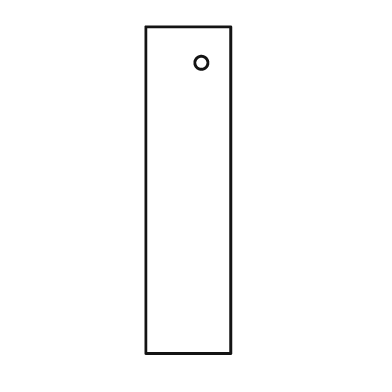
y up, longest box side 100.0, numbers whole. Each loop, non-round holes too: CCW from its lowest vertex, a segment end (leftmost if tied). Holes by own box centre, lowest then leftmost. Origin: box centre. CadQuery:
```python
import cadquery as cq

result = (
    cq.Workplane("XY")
    .moveTo(-13.0, -50.0)
    .lineTo(13.0, -50.0)
    .lineTo(13.0, 50.0)
    .lineTo(-13.0, 50.0)
    .close()
    .moveTo(4.0, 39.0)
    .circle(2.0)
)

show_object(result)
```